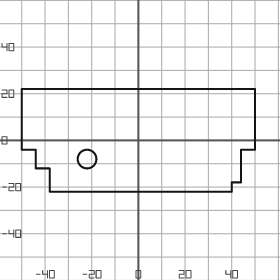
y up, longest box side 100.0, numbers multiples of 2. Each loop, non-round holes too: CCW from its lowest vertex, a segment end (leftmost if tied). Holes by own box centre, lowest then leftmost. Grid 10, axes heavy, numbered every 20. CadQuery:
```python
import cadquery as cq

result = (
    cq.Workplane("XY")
    .moveTo(-38.0, -22.0)
    .lineTo(40.0, -22.0)
    .lineTo(40.0, -18.0)
    .lineTo(44.0, -18.0)
    .lineTo(44.0, -4.0)
    .lineTo(50.0, -4.0)
    .lineTo(50.0, 22.0)
    .lineTo(-50.0, 22.0)
    .lineTo(-50.0, -4.0)
    .lineTo(-44.0, -4.0)
    .lineTo(-44.0, -12.0)
    .lineTo(-38.0, -12.0)
    .close()
    .moveTo(-22.0, -8.0)
    .circle(4.0)
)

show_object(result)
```